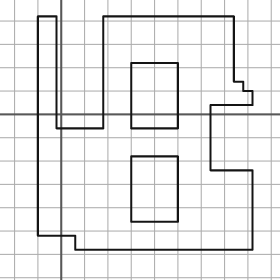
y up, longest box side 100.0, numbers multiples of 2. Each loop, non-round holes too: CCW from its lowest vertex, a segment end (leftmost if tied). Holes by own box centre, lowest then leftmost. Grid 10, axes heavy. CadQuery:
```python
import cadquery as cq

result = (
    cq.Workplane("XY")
    .moveTo(6.0, -58.0)
    .lineTo(82.0, -58.0)
    .lineTo(82.0, -24.0)
    .lineTo(64.0, -24.0)
    .lineTo(64.0, 4.0)
    .lineTo(82.0, 4.0)
    .lineTo(82.0, 10.0)
    .lineTo(78.0, 10.0)
    .lineTo(78.0, 14.0)
    .lineTo(74.0, 14.0)
    .lineTo(74.0, 42.0)
    .lineTo(18.0, 42.0)
    .lineTo(18.0, -6.0)
    .lineTo(-2.0, -6.0)
    .lineTo(-2.0, 42.0)
    .lineTo(-10.0, 42.0)
    .lineTo(-10.0, -52.0)
    .lineTo(6.0, -52.0)
    .close()
    .moveTo(30.0, -46.0)
    .lineTo(50.0, -46.0)
    .lineTo(50.0, -18.0)
    .lineTo(30.0, -18.0)
    .close()
    .moveTo(30.0, -6.0)
    .lineTo(50.0, -6.0)
    .lineTo(50.0, 22.0)
    .lineTo(30.0, 22.0)
    .close()
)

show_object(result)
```